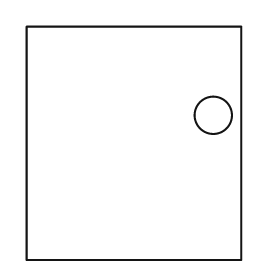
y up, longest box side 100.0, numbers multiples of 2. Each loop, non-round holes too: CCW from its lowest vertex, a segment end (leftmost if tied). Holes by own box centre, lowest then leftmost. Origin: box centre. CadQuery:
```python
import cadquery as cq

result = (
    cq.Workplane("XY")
    .moveTo(-46.0, -50.0)
    .lineTo(46.0, -50.0)
    .lineTo(46.0, 50.0)
    .lineTo(-46.0, 50.0)
    .close()
    .moveTo(34.0, 12.0)
    .circle(8.0)
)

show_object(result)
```